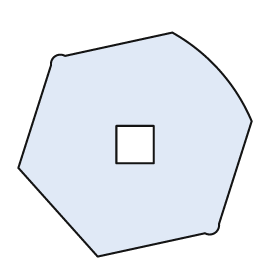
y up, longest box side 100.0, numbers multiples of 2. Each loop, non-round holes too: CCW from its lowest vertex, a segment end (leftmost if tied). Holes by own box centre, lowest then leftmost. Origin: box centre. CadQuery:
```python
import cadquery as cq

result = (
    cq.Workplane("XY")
    .moveTo(-16.0, -48.0)
    .lineTo(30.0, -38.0)
    .threePointArc((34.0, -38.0), (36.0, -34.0))
    .lineTo(50.0, 10.0)
    .threePointArc((36.0, 32.0), (16.0, 48.0))
    .lineTo(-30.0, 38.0)
    .threePointArc((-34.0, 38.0), (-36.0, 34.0))
    .lineTo(-50.0, -10.0)
    .close()
    .moveTo(-8.0, -8.0)
    .lineTo(8.0, -8.0)
    .lineTo(8.0, 8.0)
    .lineTo(-8.0, 8.0)
    .close()
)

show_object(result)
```